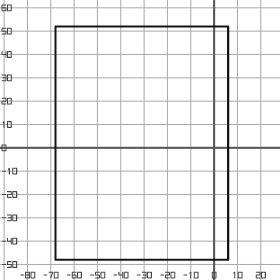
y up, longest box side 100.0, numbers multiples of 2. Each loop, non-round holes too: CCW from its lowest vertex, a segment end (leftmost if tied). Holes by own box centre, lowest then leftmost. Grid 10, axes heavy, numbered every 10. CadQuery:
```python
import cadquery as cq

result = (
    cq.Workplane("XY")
    .moveTo(-68.0, -48.0)
    .lineTo(6.0, -48.0)
    .lineTo(6.0, 52.0)
    .lineTo(-68.0, 52.0)
    .close()
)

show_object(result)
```